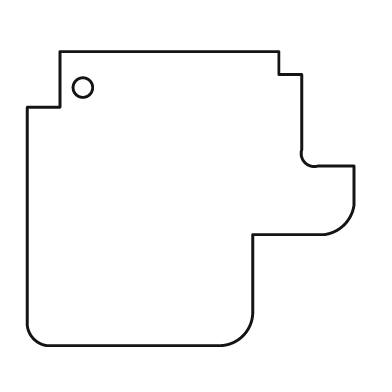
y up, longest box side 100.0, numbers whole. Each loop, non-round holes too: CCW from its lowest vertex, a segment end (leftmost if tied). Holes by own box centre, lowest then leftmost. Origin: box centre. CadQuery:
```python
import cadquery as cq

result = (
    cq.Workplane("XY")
    .moveTo(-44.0, -45.0)
    .lineTo(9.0, -45.0)
    .threePointArc((16.0, -42.0), (19.0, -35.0))
    .lineTo(19.0, -11.0)
    .lineTo(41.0, -11.0)
    .threePointArc((47.0, -8.0), (50.0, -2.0))
    .lineTo(50.0, 10.0)
    .lineTo(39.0, 10.0)
    .threePointArc((35.0, 11.0), (34.0, 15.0))
    .lineTo(34.0, 38.0)
    .lineTo(27.0, 38.0)
    .lineTo(27.0, 45.0)
    .lineTo(-40.0, 45.0)
    .lineTo(-40.0, 28.0)
    .lineTo(-50.0, 28.0)
    .lineTo(-50.0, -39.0)
    .threePointArc((-48.0, -43.0), (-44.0, -45.0))
    .close()
    .moveTo(-33.0, 34.0)
    .circle(3.0)
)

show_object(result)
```